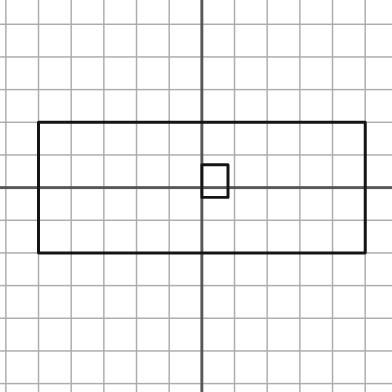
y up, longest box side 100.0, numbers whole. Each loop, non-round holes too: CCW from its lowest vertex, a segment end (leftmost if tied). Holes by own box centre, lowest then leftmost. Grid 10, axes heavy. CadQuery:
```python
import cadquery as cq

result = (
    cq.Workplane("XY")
    .moveTo(-50.0, -20.0)
    .lineTo(50.0, -20.0)
    .lineTo(50.0, 20.0)
    .lineTo(-50.0, 20.0)
    .close()
    .moveTo(0.0, -3.0)
    .lineTo(8.0, -3.0)
    .lineTo(8.0, 7.0)
    .lineTo(0.0, 7.0)
    .close()
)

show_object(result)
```